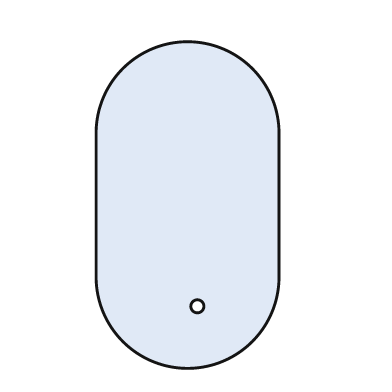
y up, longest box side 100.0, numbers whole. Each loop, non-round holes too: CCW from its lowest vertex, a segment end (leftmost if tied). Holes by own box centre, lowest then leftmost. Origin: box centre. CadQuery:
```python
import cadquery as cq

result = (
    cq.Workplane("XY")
    .moveTo(-28.0, -22.0)
    .threePointArc((0.0, -50.0), (28.0, -22.0))
    .lineTo(28.0, 22.0)
    .threePointArc((0.0, 50.0), (-28.0, 22.0))
    .close()
    .moveTo(3.0, -31.0)
    .circle(2.0)
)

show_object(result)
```